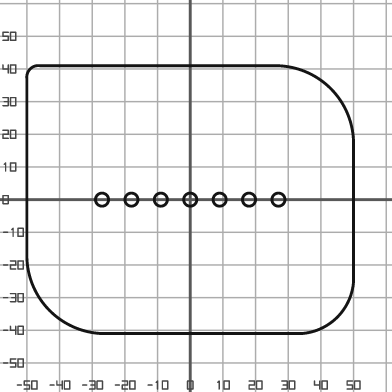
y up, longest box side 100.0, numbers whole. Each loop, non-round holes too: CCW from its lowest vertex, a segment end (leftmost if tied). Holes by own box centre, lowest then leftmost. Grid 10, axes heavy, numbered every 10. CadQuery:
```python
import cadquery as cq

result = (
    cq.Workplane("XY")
    .moveTo(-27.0, -41.0)
    .lineTo(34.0, -41.0)
    .threePointArc((45.0, -36.0), (50.0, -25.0))
    .lineTo(50.0, 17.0)
    .threePointArc((43.0, 34.0), (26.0, 41.0))
    .lineTo(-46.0, 41.0)
    .threePointArc((-49.0, 40.0), (-50.0, 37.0))
    .lineTo(-50.0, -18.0)
    .threePointArc((-43.0, -34.0), (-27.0, -41.0))
    .close()
    .moveTo(-27.0, 0.0)
    .circle(2.0)
    .moveTo(-18.0, 0.0)
    .circle(2.0)
    .moveTo(-9.0, 0.0)
    .circle(2.0)
    .moveTo(0.0, 0.0)
    .circle(2.0)
    .moveTo(9.0, 0.0)
    .circle(2.0)
    .moveTo(18.0, 0.0)
    .circle(2.0)
    .moveTo(27.0, 0.0)
    .circle(2.0)
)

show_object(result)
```